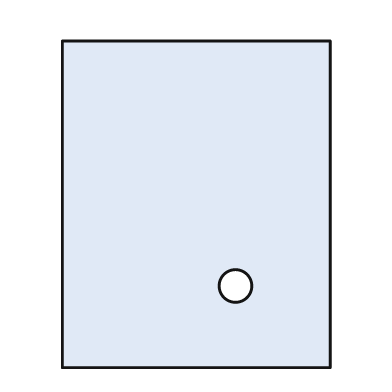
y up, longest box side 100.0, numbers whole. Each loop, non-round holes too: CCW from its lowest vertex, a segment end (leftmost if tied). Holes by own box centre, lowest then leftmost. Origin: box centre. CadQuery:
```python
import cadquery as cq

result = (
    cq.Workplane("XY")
    .moveTo(-41.0, -50.0)
    .lineTo(41.0, -50.0)
    .lineTo(41.0, 50.0)
    .lineTo(-41.0, 50.0)
    .close()
    .moveTo(12.0, -25.0)
    .circle(5.0)
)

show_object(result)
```